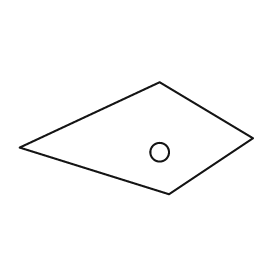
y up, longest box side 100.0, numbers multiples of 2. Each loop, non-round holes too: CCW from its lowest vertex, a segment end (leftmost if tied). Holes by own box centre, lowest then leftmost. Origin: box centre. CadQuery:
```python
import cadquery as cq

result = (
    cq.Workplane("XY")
    .moveTo(14.0, -24.0)
    .lineTo(50.0, 0.0)
    .lineTo(10.0, 24.0)
    .lineTo(-50.0, -4.0)
    .close()
    .moveTo(10.0, -6.0)
    .circle(4.0)
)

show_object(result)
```